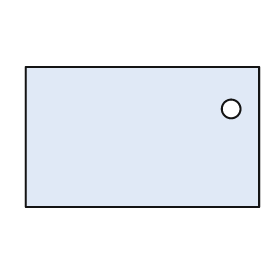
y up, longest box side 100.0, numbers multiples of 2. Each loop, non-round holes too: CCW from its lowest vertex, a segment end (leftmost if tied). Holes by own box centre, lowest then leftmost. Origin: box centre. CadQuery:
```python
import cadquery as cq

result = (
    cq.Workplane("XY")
    .moveTo(-50.0, -30.0)
    .lineTo(50.0, -30.0)
    .lineTo(50.0, 30.0)
    .lineTo(-50.0, 30.0)
    .close()
    .moveTo(38.0, 12.0)
    .circle(4.0)
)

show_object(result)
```